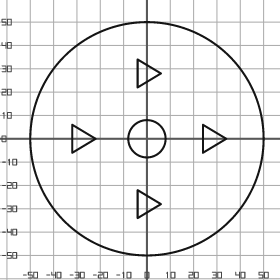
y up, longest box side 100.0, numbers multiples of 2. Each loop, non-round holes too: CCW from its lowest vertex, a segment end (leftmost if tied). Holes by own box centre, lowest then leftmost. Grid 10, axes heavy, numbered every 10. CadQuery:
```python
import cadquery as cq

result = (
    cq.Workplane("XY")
    .moveTo(0.0, 0.0)
    .circle(50.0)
    .moveTo(-4.0, -34.0)
    .lineTo(6.0, -28.0)
    .lineTo(-4.0, -22.0)
    .close()
    .moveTo(-32.0, -6.0)
    .lineTo(-22.0, 0.0)
    .lineTo(-32.0, 6.0)
    .close()
    .moveTo(0.0, 0.0)
    .circle(8.0)
    .moveTo(24.0, -6.0)
    .lineTo(34.0, 0.0)
    .lineTo(24.0, 6.0)
    .close()
    .moveTo(-4.0, 22.0)
    .lineTo(6.0, 28.0)
    .lineTo(-4.0, 34.0)
    .close()
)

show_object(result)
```